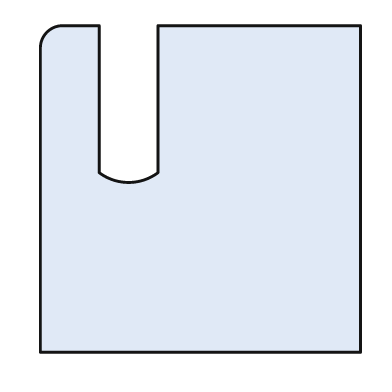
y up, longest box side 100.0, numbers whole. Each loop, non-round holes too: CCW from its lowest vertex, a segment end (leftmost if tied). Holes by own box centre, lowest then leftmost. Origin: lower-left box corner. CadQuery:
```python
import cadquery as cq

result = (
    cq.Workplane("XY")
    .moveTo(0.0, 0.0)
    .lineTo(98.0, 0.0)
    .lineTo(98.0, 100.0)
    .lineTo(36.0, 100.0)
    .lineTo(36.0, 55.0)
    .threePointArc((27.0, 52.0), (18.0, 55.0))
    .lineTo(18.0, 100.0)
    .lineTo(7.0, 100.0)
    .threePointArc((2.0, 98.0), (0.0, 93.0))
    .close()
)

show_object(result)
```